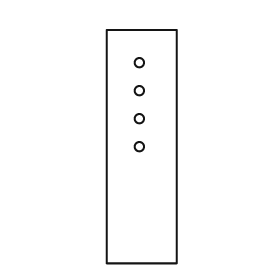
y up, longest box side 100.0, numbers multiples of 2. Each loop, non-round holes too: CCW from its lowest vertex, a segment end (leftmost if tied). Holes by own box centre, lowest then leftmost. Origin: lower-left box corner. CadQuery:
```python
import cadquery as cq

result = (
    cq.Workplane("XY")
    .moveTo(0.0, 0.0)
    .lineTo(30.0, 0.0)
    .lineTo(30.0, 100.0)
    .lineTo(0.0, 100.0)
    .close()
    .moveTo(14.0, 50.0)
    .circle(2.0)
    .moveTo(14.0, 62.0)
    .circle(2.0)
    .moveTo(14.0, 74.0)
    .circle(2.0)
    .moveTo(14.0, 86.0)
    .circle(2.0)
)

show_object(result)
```